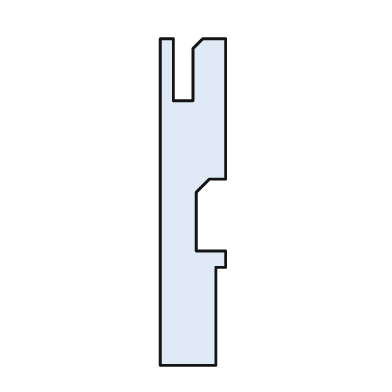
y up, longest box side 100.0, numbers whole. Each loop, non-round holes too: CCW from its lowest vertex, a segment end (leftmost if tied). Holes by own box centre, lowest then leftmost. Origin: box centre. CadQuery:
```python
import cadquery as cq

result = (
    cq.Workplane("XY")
    .moveTo(-10.0, -50.0)
    .lineTo(7.0, -50.0)
    .lineTo(7.0, -20.0)
    .lineTo(10.0, -20.0)
    .lineTo(10.0, -15.0)
    .lineTo(1.0, -15.0)
    .lineTo(1.0, 3.0)
    .lineTo(5.0, 7.0)
    .lineTo(10.0, 7.0)
    .lineTo(10.0, 50.0)
    .lineTo(3.0, 50.0)
    .lineTo(0.0, 47.0)
    .lineTo(0.0, 31.0)
    .lineTo(-6.0, 31.0)
    .lineTo(-6.0, 50.0)
    .lineTo(-10.0, 50.0)
    .close()
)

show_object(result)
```